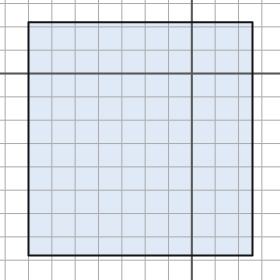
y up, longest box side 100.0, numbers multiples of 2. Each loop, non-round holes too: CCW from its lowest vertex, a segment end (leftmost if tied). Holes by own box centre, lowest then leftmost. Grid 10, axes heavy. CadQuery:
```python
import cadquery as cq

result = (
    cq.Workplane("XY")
    .moveTo(-70.0, -78.0)
    .lineTo(26.0, -78.0)
    .lineTo(26.0, 22.0)
    .lineTo(-70.0, 22.0)
    .close()
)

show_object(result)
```